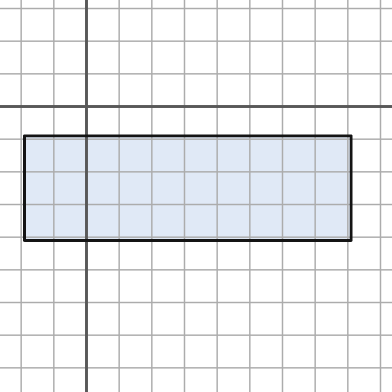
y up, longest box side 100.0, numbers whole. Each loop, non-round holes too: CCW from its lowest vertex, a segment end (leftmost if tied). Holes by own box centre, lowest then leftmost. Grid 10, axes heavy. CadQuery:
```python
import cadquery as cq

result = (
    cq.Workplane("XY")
    .moveTo(-19.0, -41.0)
    .lineTo(81.0, -41.0)
    .lineTo(81.0, -9.0)
    .lineTo(-19.0, -9.0)
    .close()
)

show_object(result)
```